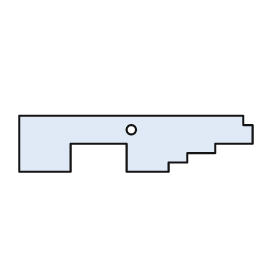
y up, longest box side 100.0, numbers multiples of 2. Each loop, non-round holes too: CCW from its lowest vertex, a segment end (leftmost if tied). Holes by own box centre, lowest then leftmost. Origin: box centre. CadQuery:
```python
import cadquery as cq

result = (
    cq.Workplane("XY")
    .moveTo(-50.0, -12.0)
    .lineTo(-28.0, -12.0)
    .lineTo(-28.0, 0.0)
    .lineTo(-4.0, 0.0)
    .lineTo(-4.0, -12.0)
    .lineTo(14.0, -12.0)
    .lineTo(14.0, -8.0)
    .lineTo(22.0, -8.0)
    .lineTo(22.0, -4.0)
    .lineTo(34.0, -4.0)
    .lineTo(34.0, 0.0)
    .lineTo(50.0, 0.0)
    .lineTo(50.0, 8.0)
    .lineTo(46.0, 8.0)
    .lineTo(46.0, 12.0)
    .lineTo(-50.0, 12.0)
    .close()
    .moveTo(-2.0, 6.0)
    .circle(2.0)
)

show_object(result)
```